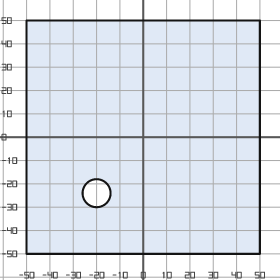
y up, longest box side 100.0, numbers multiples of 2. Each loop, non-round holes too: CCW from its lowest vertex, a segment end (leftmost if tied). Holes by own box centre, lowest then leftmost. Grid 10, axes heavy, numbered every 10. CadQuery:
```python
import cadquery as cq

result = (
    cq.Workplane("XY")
    .moveTo(-50.0, -50.0)
    .lineTo(50.0, -50.0)
    .lineTo(50.0, 50.0)
    .lineTo(-50.0, 50.0)
    .close()
    .moveTo(-20.0, -24.0)
    .circle(6.0)
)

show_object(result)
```